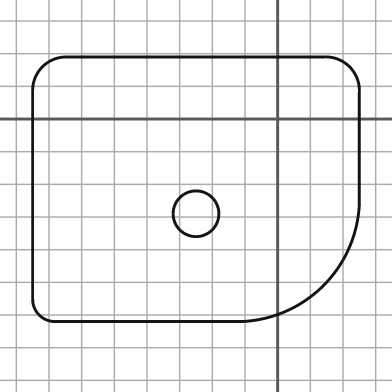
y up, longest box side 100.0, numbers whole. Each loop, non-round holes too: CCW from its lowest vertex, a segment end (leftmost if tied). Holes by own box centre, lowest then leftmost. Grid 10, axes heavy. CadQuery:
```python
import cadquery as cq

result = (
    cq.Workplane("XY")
    .moveTo(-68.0, -62.0)
    .lineTo(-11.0, -62.0)
    .threePointArc((14.0, -51.0), (25.0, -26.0))
    .lineTo(25.0, 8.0)
    .threePointArc((22.0, 16.0), (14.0, 19.0))
    .lineTo(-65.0, 19.0)
    .threePointArc((-72.0, 16.0), (-75.0, 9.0))
    .lineTo(-75.0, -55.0)
    .threePointArc((-73.0, -60.0), (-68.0, -62.0))
    .close()
    .moveTo(-25.0, -29.0)
    .circle(7.0)
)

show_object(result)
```